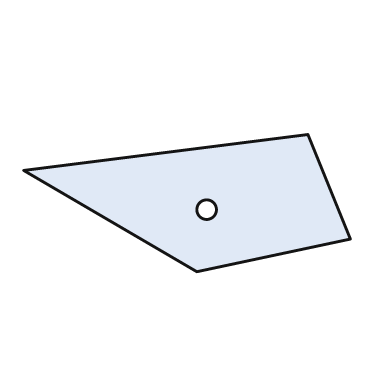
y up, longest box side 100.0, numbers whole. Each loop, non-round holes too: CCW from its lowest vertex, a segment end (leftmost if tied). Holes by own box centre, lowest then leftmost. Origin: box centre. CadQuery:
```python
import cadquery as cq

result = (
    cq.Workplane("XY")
    .moveTo(3.0, -21.0)
    .lineTo(50.0, -11.0)
    .lineTo(37.0, 21.0)
    .lineTo(-50.0, 10.0)
    .close()
    .moveTo(6.0, -2.0)
    .circle(3.0)
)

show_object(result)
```